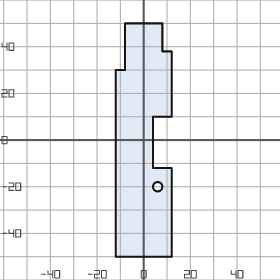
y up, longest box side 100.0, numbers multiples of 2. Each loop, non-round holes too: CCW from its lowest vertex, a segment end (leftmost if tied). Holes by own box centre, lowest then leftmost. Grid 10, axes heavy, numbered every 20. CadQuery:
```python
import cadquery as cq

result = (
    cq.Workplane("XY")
    .moveTo(-12.0, -50.0)
    .lineTo(12.0, -50.0)
    .lineTo(12.0, -12.0)
    .lineTo(4.0, -12.0)
    .lineTo(4.0, 10.0)
    .lineTo(12.0, 10.0)
    .lineTo(12.0, 38.0)
    .lineTo(8.0, 38.0)
    .lineTo(8.0, 50.0)
    .lineTo(-8.0, 50.0)
    .lineTo(-8.0, 30.0)
    .lineTo(-12.0, 30.0)
    .close()
    .moveTo(6.0, -20.0)
    .circle(2.0)
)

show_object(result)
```